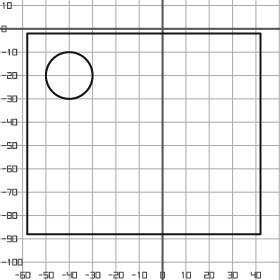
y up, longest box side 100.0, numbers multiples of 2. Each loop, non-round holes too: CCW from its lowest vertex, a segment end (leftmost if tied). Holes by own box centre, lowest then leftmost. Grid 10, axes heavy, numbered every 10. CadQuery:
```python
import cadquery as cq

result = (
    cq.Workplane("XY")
    .moveTo(-58.0, -88.0)
    .lineTo(42.0, -88.0)
    .lineTo(42.0, -2.0)
    .lineTo(-58.0, -2.0)
    .close()
    .moveTo(-40.0, -20.0)
    .circle(10.0)
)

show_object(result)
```